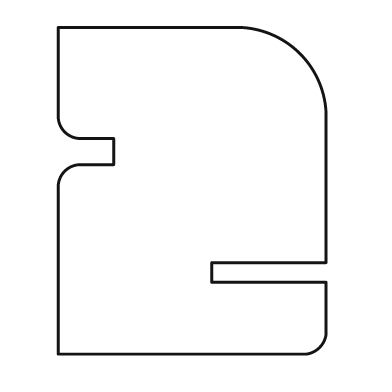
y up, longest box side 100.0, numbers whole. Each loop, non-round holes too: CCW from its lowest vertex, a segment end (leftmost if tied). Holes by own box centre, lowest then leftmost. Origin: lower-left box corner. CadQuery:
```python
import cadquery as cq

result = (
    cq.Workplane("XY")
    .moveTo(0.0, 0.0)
    .lineTo(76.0, 0.0)
    .threePointArc((80.0, 2.0), (82.0, 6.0))
    .lineTo(82.0, 22.0)
    .lineTo(47.0, 22.0)
    .lineTo(47.0, 28.0)
    .lineTo(82.0, 28.0)
    .lineTo(82.0, 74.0)
    .threePointArc((74.0, 92.0), (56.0, 100.0))
    .lineTo(0.0, 100.0)
    .lineTo(0.0, 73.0)
    .threePointArc((2.0, 68.0), (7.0, 66.0))
    .lineTo(17.0, 66.0)
    .lineTo(17.0, 58.0)
    .lineTo(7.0, 58.0)
    .threePointArc((2.0, 56.0), (0.0, 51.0))
    .close()
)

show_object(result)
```